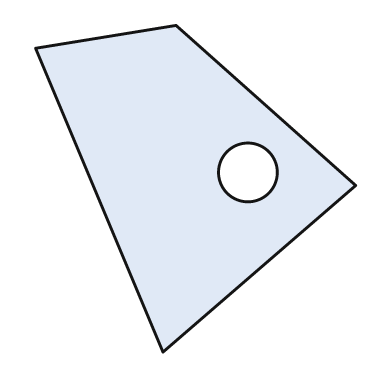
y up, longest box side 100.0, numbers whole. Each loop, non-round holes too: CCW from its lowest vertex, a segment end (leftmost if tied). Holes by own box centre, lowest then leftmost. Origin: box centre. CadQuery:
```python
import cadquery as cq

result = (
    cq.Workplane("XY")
    .moveTo(-10.0, -50.0)
    .lineTo(49.0, 1.0)
    .lineTo(-6.0, 50.0)
    .lineTo(-49.0, 43.0)
    .close()
    .moveTo(16.0, 5.0)
    .circle(9.0)
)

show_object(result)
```